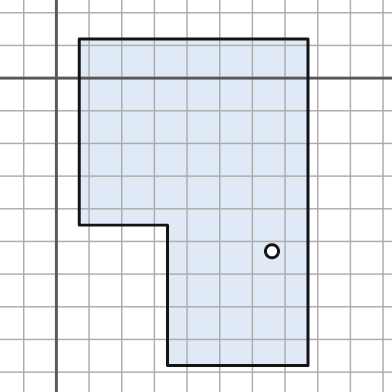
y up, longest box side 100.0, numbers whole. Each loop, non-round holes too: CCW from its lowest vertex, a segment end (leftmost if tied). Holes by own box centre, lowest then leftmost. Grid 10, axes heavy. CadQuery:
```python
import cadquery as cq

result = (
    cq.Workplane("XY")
    .moveTo(34.0, -88.0)
    .lineTo(77.0, -88.0)
    .lineTo(77.0, 12.0)
    .lineTo(7.0, 12.0)
    .lineTo(7.0, -45.0)
    .lineTo(34.0, -45.0)
    .close()
    .moveTo(66.0, -53.0)
    .circle(2.0)
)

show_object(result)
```